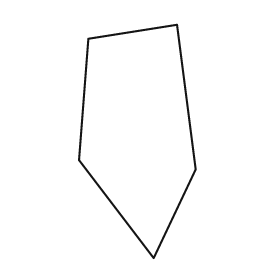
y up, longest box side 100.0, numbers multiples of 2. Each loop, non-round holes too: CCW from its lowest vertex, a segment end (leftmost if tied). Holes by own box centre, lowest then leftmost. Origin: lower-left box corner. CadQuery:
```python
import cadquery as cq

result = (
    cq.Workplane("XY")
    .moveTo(32.0, 0.0)
    .lineTo(50.0, 38.0)
    .lineTo(42.0, 100.0)
    .lineTo(4.0, 94.0)
    .lineTo(0.0, 42.0)
    .close()
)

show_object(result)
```